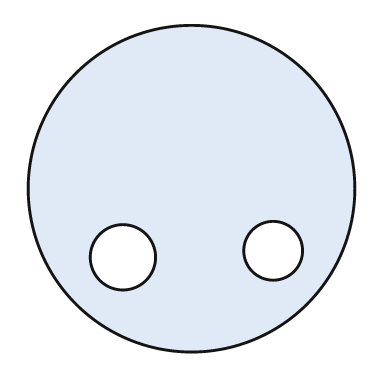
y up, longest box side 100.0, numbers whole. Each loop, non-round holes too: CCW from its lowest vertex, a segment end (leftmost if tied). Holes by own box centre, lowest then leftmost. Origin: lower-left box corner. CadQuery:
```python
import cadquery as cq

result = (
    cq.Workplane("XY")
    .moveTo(50.0, 50.0)
    .circle(50.0)
    .moveTo(29.0, 29.0)
    .circle(10.0)
    .moveTo(75.0, 31.0)
    .circle(9.0)
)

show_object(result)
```